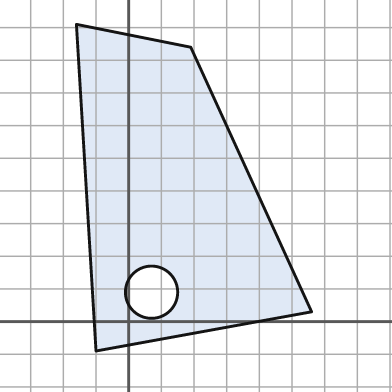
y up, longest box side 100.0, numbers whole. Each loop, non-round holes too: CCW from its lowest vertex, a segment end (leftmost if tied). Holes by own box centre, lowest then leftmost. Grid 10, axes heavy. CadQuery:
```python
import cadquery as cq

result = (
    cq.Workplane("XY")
    .moveTo(-10.0, -9.0)
    .lineTo(56.0, 3.0)
    .lineTo(19.0, 84.0)
    .lineTo(-16.0, 91.0)
    .close()
    .moveTo(7.0, 9.0)
    .circle(8.0)
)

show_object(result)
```